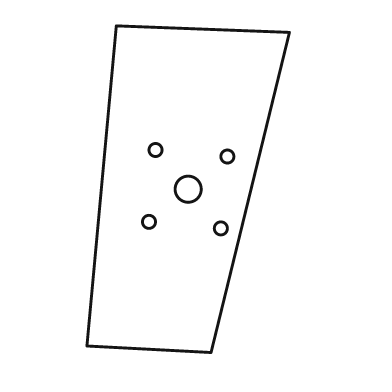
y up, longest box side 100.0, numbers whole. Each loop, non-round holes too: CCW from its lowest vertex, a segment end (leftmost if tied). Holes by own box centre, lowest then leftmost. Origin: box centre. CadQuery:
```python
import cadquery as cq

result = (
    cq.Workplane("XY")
    .moveTo(7.0, -50.0)
    .lineTo(31.0, 48.0)
    .lineTo(-22.0, 50.0)
    .lineTo(-31.0, -48.0)
    .close()
    .moveTo(10.0, -12.0)
    .circle(2.0)
    .moveTo(-12.0, -10.0)
    .circle(2.0)
    .moveTo(0.0, 0.0)
    .circle(4.0)
    .moveTo(12.0, 10.0)
    .circle(2.0)
    .moveTo(-10.0, 12.0)
    .circle(2.0)
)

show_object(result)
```